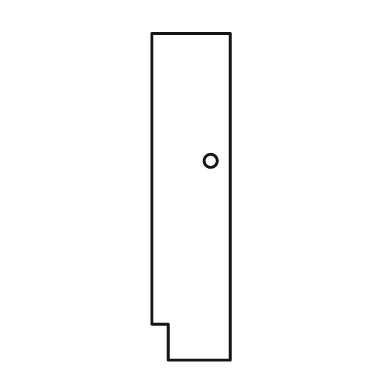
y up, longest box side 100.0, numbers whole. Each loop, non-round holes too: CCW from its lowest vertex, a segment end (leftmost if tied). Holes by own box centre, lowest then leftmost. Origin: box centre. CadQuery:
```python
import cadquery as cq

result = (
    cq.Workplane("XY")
    .moveTo(-7.0, -50.0)
    .lineTo(12.0, -50.0)
    .lineTo(12.0, 50.0)
    .lineTo(-12.0, 50.0)
    .lineTo(-12.0, -39.0)
    .lineTo(-7.0, -39.0)
    .close()
    .moveTo(6.0, 11.0)
    .circle(2.0)
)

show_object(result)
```